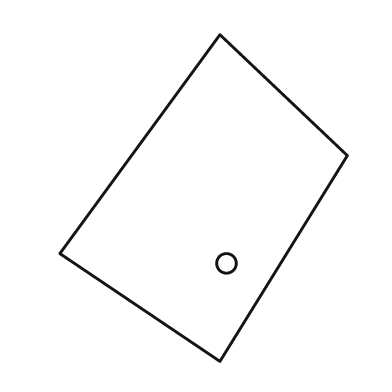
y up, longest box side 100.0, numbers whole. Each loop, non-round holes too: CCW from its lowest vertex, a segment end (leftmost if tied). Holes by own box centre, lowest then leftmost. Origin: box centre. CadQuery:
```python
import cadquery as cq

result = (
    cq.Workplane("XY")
    .moveTo(5.0, -50.0)
    .lineTo(44.0, 13.0)
    .lineTo(5.0, 50.0)
    .lineTo(-44.0, -17.0)
    .close()
    .moveTo(7.0, -20.0)
    .circle(3.0)
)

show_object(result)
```